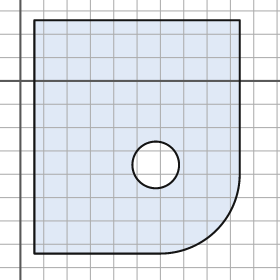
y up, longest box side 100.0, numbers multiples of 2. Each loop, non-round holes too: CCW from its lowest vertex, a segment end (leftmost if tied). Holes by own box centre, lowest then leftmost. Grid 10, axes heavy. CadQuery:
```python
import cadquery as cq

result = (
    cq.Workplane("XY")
    .moveTo(6.0, -74.0)
    .lineTo(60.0, -74.0)
    .threePointArc((84.0, -64.0), (94.0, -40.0))
    .lineTo(94.0, 26.0)
    .lineTo(6.0, 26.0)
    .close()
    .moveTo(58.0, -36.0)
    .circle(10.0)
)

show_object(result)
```